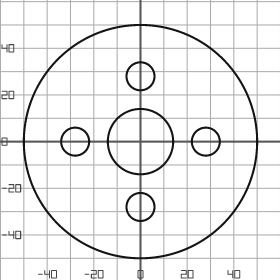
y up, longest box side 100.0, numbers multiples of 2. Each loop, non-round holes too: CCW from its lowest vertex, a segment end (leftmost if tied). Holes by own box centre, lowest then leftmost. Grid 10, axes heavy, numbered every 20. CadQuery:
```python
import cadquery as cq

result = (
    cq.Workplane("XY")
    .moveTo(0.0, 0.0)
    .circle(50.0)
    .moveTo(0.0, -28.0)
    .circle(6.0)
    .moveTo(-28.0, 0.0)
    .circle(6.0)
    .moveTo(0.0, 0.0)
    .circle(14.0)
    .moveTo(28.0, 0.0)
    .circle(6.0)
    .moveTo(0.0, 28.0)
    .circle(6.0)
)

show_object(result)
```